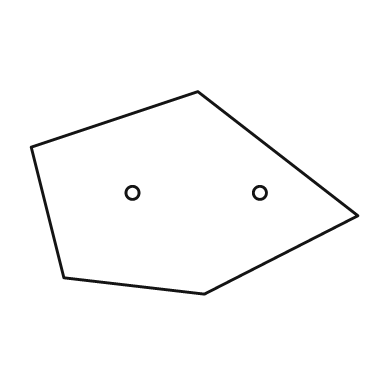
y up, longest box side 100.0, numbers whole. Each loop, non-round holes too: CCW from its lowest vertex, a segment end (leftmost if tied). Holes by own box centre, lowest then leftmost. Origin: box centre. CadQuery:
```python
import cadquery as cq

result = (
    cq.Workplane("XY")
    .moveTo(3.0, -31.0)
    .lineTo(50.0, -7.0)
    .lineTo(1.0, 31.0)
    .lineTo(-50.0, 14.0)
    .lineTo(-40.0, -26.0)
    .close()
    .moveTo(-19.0, 0.0)
    .circle(2.0)
    .moveTo(20.0, 0.0)
    .circle(2.0)
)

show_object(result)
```